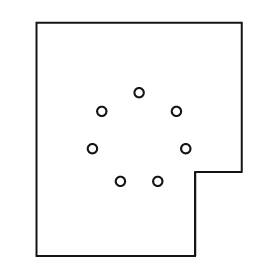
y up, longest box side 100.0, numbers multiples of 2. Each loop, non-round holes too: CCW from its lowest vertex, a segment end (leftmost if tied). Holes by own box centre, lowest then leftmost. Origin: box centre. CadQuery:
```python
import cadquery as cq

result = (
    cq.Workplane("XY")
    .moveTo(-44.0, -50.0)
    .lineTo(24.0, -50.0)
    .lineTo(24.0, -14.0)
    .lineTo(44.0, -14.0)
    .lineTo(44.0, 50.0)
    .lineTo(-44.0, 50.0)
    .close()
    .moveTo(-8.0, -18.0)
    .circle(2.0)
    .moveTo(8.0, -18.0)
    .circle(2.0)
    .moveTo(-20.0, -4.0)
    .circle(2.0)
    .moveTo(20.0, -4.0)
    .circle(2.0)
    .moveTo(-16.0, 12.0)
    .circle(2.0)
    .moveTo(16.0, 12.0)
    .circle(2.0)
    .moveTo(0.0, 20.0)
    .circle(2.0)
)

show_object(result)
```